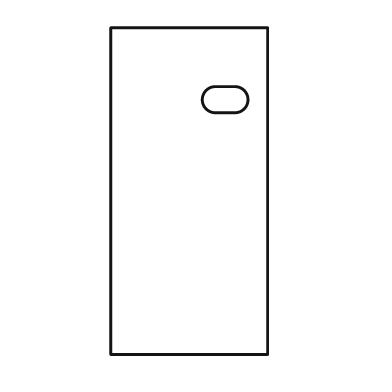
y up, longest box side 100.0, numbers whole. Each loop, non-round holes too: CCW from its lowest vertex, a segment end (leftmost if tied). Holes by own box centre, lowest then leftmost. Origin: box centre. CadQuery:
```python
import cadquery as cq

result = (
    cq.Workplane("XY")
    .moveTo(-24.0, -50.0)
    .lineTo(24.0, -50.0)
    .lineTo(24.0, 50.0)
    .lineTo(-24.0, 50.0)
    .close()
    .moveTo(8.0, 24.0)
    .lineTo(14.0, 24.0)
    .threePointArc((18.0, 28.0), (14.0, 32.0))
    .lineTo(8.0, 32.0)
    .threePointArc((4.0, 28.0), (8.0, 24.0))
    .close()
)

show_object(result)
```